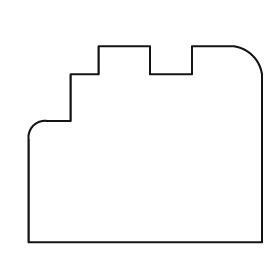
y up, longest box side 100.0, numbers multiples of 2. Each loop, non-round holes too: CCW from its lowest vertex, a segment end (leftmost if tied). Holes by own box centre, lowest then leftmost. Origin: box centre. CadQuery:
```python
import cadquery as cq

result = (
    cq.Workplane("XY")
    .moveTo(-50.0, -42.0)
    .lineTo(50.0, -42.0)
    .lineTo(50.0, 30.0)
    .threePointArc((46.0, 38.0), (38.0, 42.0))
    .lineTo(20.0, 42.0)
    .lineTo(20.0, 30.0)
    .lineTo(2.0, 30.0)
    .lineTo(2.0, 42.0)
    .lineTo(-20.0, 42.0)
    .lineTo(-20.0, 30.0)
    .lineTo(-32.0, 30.0)
    .lineTo(-32.0, 10.0)
    .lineTo(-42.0, 10.0)
    .threePointArc((-48.0, 8.0), (-50.0, 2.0))
    .close()
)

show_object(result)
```